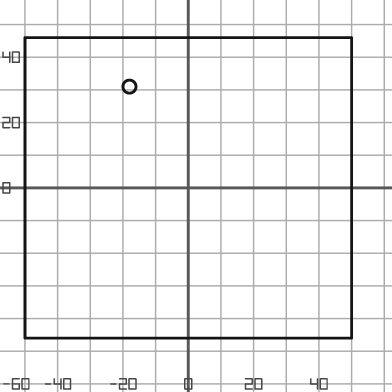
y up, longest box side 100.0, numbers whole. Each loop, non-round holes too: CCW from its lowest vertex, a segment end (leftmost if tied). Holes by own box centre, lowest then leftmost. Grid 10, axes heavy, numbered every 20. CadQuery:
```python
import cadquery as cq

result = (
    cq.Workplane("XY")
    .moveTo(-50.0, -46.0)
    .lineTo(50.0, -46.0)
    .lineTo(50.0, 46.0)
    .lineTo(-50.0, 46.0)
    .close()
    .moveTo(-18.0, 31.0)
    .circle(2.0)
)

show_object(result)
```